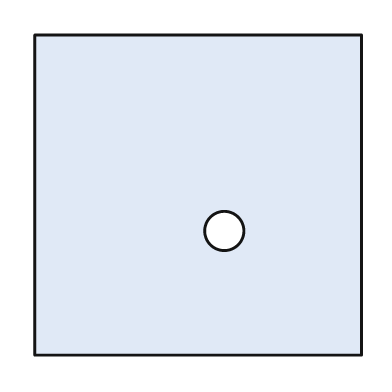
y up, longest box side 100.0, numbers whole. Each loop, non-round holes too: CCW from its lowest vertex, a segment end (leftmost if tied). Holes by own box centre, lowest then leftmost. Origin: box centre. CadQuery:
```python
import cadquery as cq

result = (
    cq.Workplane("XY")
    .moveTo(-50.0, -49.0)
    .lineTo(50.0, -49.0)
    .lineTo(50.0, 49.0)
    .lineTo(-50.0, 49.0)
    .close()
    .moveTo(8.0, -11.0)
    .circle(6.0)
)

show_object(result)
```